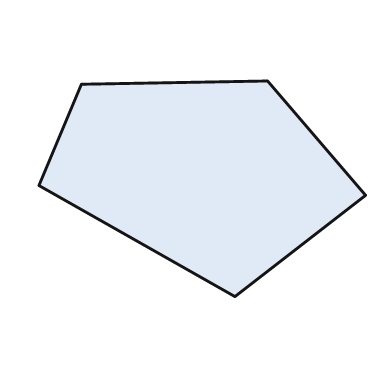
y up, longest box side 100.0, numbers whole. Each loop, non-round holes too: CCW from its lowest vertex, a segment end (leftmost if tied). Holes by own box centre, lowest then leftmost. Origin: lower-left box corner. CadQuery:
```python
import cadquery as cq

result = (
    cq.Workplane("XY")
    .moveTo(60.0, 0.0)
    .lineTo(100.0, 31.0)
    .lineTo(70.0, 66.0)
    .lineTo(13.0, 65.0)
    .lineTo(0.0, 34.0)
    .close()
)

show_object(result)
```